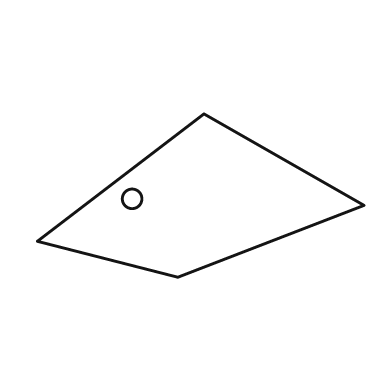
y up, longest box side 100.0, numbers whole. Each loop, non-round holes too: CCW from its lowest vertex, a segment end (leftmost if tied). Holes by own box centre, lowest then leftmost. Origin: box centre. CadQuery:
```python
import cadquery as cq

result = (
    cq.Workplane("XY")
    .moveTo(-7.0, -25.0)
    .lineTo(50.0, -3.0)
    .lineTo(1.0, 25.0)
    .lineTo(-50.0, -14.0)
    .close()
    .moveTo(-21.0, -1.0)
    .circle(3.0)
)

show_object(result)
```